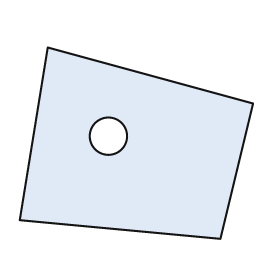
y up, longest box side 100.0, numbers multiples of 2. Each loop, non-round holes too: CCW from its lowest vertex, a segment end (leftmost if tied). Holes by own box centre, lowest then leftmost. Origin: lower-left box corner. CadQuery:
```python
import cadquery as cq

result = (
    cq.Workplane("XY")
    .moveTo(86.0, 0.0)
    .lineTo(100.0, 58.0)
    .lineTo(12.0, 82.0)
    .lineTo(0.0, 8.0)
    .close()
    .moveTo(38.0, 44.0)
    .circle(8.0)
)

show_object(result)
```